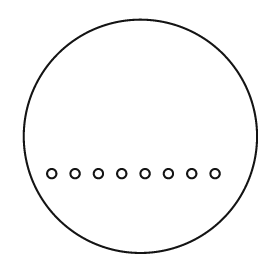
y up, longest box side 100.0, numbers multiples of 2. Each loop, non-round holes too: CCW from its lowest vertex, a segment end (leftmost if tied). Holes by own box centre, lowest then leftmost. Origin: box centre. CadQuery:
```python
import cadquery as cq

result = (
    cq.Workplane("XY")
    .moveTo(0.0, 0.0)
    .circle(50.0)
    .moveTo(-38.0, -16.0)
    .circle(2.0)
    .moveTo(-28.0, -16.0)
    .circle(2.0)
    .moveTo(-18.0, -16.0)
    .circle(2.0)
    .moveTo(-8.0, -16.0)
    .circle(2.0)
    .moveTo(2.0, -16.0)
    .circle(2.0)
    .moveTo(12.0, -16.0)
    .circle(2.0)
    .moveTo(22.0, -16.0)
    .circle(2.0)
    .moveTo(32.0, -16.0)
    .circle(2.0)
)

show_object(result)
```